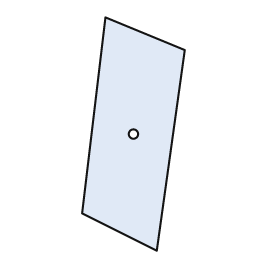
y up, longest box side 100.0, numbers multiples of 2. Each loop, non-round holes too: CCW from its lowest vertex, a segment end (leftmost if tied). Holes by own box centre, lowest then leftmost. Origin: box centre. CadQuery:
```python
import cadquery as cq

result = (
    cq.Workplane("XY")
    .moveTo(10.0, -50.0)
    .lineTo(22.0, 36.0)
    .lineTo(-12.0, 50.0)
    .lineTo(-22.0, -34.0)
    .close()
    .moveTo(0.0, 0.0)
    .circle(2.0)
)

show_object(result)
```